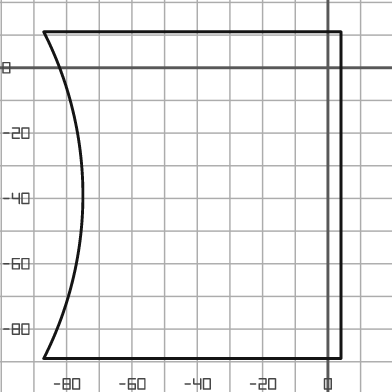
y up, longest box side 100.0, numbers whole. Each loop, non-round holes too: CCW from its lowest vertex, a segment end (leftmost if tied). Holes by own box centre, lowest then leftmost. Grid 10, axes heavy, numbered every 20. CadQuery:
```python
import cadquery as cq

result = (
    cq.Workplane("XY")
    .moveTo(-87.0, -89.0)
    .lineTo(4.0, -89.0)
    .lineTo(4.0, 11.0)
    .lineTo(-87.0, 11.0)
    .threePointArc((-75.0, -39.0), (-87.0, -89.0))
    .close()
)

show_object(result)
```